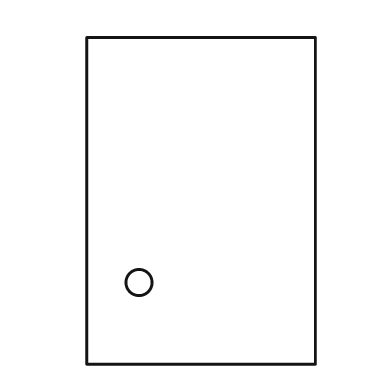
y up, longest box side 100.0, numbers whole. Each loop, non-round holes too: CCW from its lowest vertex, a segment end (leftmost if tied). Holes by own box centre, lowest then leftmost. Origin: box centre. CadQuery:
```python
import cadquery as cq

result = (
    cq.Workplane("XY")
    .moveTo(-35.0, -50.0)
    .lineTo(35.0, -50.0)
    .lineTo(35.0, 50.0)
    .lineTo(-35.0, 50.0)
    .close()
    .moveTo(-19.0, -25.0)
    .circle(4.0)
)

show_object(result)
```